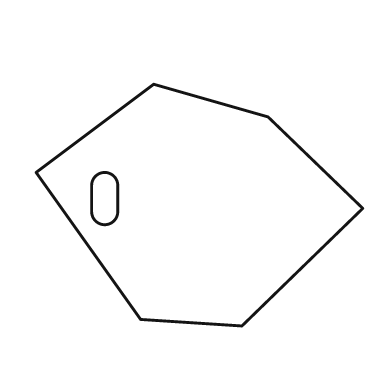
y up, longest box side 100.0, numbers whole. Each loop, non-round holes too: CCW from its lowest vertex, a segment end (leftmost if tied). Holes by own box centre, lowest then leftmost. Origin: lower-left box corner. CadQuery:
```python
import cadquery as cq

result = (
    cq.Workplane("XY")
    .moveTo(63.0, 0.0)
    .lineTo(100.0, 36.0)
    .lineTo(71.0, 64.0)
    .lineTo(36.0, 74.0)
    .lineTo(0.0, 47.0)
    .lineTo(32.0, 2.0)
    .close()
    .moveTo(17.0, 35.0)
    .threePointArc((21.0, 31.0), (25.0, 35.0))
    .lineTo(25.0, 43.0)
    .threePointArc((21.0, 47.0), (17.0, 43.0))
    .close()
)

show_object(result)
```